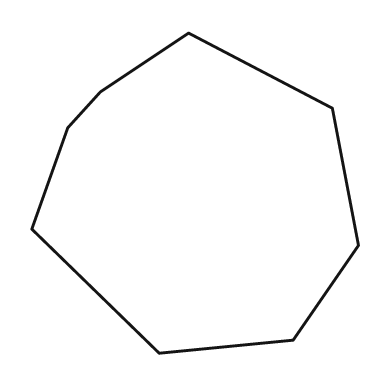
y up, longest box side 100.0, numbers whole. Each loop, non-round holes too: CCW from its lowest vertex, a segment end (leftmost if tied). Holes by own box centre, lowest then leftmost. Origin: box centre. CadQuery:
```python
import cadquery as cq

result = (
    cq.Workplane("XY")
    .moveTo(-11.0, -49.0)
    .lineTo(30.0, -45.0)
    .lineTo(50.0, -16.0)
    .lineTo(42.0, 26.0)
    .lineTo(-2.0, 49.0)
    .lineTo(-29.0, 31.0)
    .lineTo(-39.0, 20.0)
    .lineTo(-50.0, -11.0)
    .close()
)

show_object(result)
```